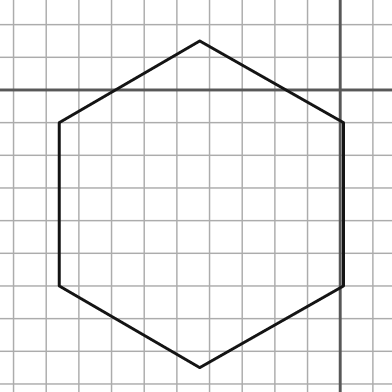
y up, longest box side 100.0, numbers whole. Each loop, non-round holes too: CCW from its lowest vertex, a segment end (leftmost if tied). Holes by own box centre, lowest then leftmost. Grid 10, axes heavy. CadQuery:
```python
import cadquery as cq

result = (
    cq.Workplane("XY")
    .moveTo(-43.0, -85.0)
    .lineTo(1.0, -60.0)
    .lineTo(1.0, -10.0)
    .lineTo(-43.0, 15.0)
    .lineTo(-86.0, -10.0)
    .lineTo(-86.0, -60.0)
    .close()
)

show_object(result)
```